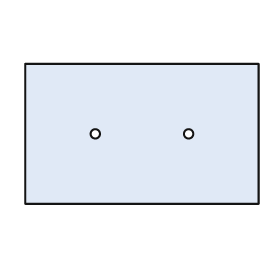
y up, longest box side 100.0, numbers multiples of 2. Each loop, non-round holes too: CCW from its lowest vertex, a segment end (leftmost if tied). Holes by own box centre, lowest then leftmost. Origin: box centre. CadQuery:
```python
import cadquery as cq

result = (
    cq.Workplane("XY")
    .moveTo(-50.0, -30.0)
    .lineTo(50.0, -30.0)
    .lineTo(50.0, 30.0)
    .lineTo(-50.0, 30.0)
    .close()
    .moveTo(-20.0, 0.0)
    .circle(2.0)
    .moveTo(20.0, 0.0)
    .circle(2.0)
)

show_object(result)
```